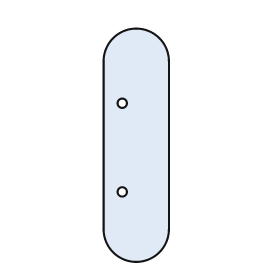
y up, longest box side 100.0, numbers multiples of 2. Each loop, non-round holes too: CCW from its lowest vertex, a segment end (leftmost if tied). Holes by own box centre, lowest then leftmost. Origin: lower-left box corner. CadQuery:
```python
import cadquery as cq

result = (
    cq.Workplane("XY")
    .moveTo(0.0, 14.0)
    .threePointArc((14.0, 0.0), (28.0, 14.0))
    .lineTo(28.0, 86.0)
    .threePointArc((14.0, 100.0), (0.0, 86.0))
    .close()
    .moveTo(8.0, 30.0)
    .circle(2.0)
    .moveTo(8.0, 68.0)
    .circle(2.0)
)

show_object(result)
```